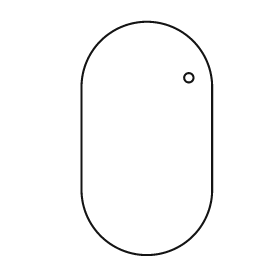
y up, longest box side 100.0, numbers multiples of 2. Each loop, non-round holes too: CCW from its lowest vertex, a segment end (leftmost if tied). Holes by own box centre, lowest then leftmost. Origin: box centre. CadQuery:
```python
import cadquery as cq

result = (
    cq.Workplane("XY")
    .moveTo(-28.0, -22.0)
    .threePointArc((0.0, -50.0), (28.0, -22.0))
    .lineTo(28.0, 22.0)
    .threePointArc((0.0, 50.0), (-28.0, 22.0))
    .close()
    .moveTo(18.0, 26.0)
    .circle(2.0)
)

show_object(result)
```